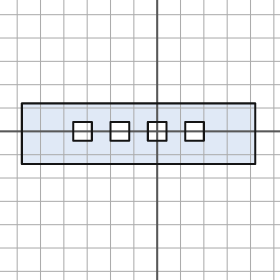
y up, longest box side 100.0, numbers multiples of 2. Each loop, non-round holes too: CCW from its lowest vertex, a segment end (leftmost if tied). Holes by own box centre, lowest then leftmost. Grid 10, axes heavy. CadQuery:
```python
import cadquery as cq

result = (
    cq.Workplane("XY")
    .moveTo(-58.0, -14.0)
    .lineTo(42.0, -14.0)
    .lineTo(42.0, 12.0)
    .lineTo(-58.0, 12.0)
    .close()
    .moveTo(-36.0, -4.0)
    .lineTo(-28.0, -4.0)
    .lineTo(-28.0, 4.0)
    .lineTo(-36.0, 4.0)
    .close()
    .moveTo(-20.0, -4.0)
    .lineTo(-12.0, -4.0)
    .lineTo(-12.0, 4.0)
    .lineTo(-20.0, 4.0)
    .close()
    .moveTo(-4.0, -4.0)
    .lineTo(4.0, -4.0)
    .lineTo(4.0, 4.0)
    .lineTo(-4.0, 4.0)
    .close()
    .moveTo(12.0, -4.0)
    .lineTo(20.0, -4.0)
    .lineTo(20.0, 4.0)
    .lineTo(12.0, 4.0)
    .close()
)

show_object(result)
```